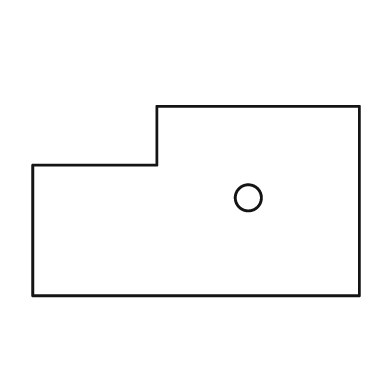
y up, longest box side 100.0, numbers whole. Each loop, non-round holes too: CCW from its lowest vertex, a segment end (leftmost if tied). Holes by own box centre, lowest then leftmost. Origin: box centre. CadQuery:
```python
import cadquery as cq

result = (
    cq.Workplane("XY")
    .moveTo(-50.0, -29.0)
    .lineTo(50.0, -29.0)
    .lineTo(50.0, 29.0)
    .lineTo(-12.0, 29.0)
    .lineTo(-12.0, 11.0)
    .lineTo(-50.0, 11.0)
    .close()
    .moveTo(16.0, 1.0)
    .circle(4.0)
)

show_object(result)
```